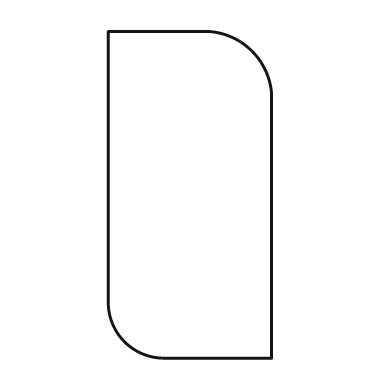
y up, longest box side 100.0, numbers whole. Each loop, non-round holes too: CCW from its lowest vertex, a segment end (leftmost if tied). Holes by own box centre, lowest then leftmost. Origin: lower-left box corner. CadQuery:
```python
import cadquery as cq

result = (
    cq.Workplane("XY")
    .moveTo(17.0, 0.0)
    .lineTo(50.0, 0.0)
    .lineTo(50.0, 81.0)
    .threePointArc((44.0, 94.0), (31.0, 100.0))
    .lineTo(0.0, 100.0)
    .lineTo(0.0, 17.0)
    .threePointArc((5.0, 5.0), (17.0, 0.0))
    .close()
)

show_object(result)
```